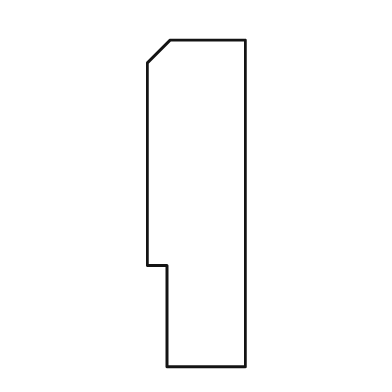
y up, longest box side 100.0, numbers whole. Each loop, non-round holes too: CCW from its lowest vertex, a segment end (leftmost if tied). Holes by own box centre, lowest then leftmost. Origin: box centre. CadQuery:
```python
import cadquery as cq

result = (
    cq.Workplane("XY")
    .moveTo(-9.0, -50.0)
    .lineTo(15.0, -50.0)
    .lineTo(15.0, 50.0)
    .lineTo(-8.0, 50.0)
    .lineTo(-15.0, 43.0)
    .lineTo(-15.0, -19.0)
    .lineTo(-9.0, -19.0)
    .close()
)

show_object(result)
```